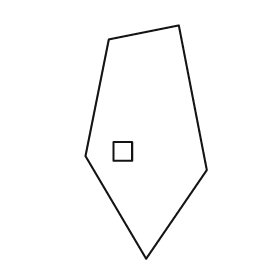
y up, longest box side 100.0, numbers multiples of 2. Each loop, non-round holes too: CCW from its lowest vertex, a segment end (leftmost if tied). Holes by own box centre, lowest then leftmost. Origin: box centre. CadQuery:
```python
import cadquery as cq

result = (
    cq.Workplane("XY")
    .moveTo(0.0, -50.0)
    .lineTo(26.0, -12.0)
    .lineTo(14.0, 50.0)
    .lineTo(-16.0, 44.0)
    .lineTo(-26.0, -6.0)
    .close()
    .moveTo(-14.0, -8.0)
    .lineTo(-6.0, -8.0)
    .lineTo(-6.0, 0.0)
    .lineTo(-14.0, 0.0)
    .close()
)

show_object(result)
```